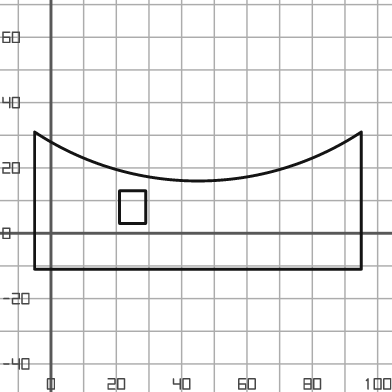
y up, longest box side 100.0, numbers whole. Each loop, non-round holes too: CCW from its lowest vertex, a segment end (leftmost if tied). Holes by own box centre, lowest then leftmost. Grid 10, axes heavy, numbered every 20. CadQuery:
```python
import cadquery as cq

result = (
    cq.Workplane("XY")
    .moveTo(-5.0, -11.0)
    .lineTo(95.0, -11.0)
    .lineTo(95.0, 31.0)
    .threePointArc((45.0, 16.0), (-5.0, 31.0))
    .close()
    .moveTo(21.0, 3.0)
    .lineTo(29.0, 3.0)
    .lineTo(29.0, 13.0)
    .lineTo(21.0, 13.0)
    .close()
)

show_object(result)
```